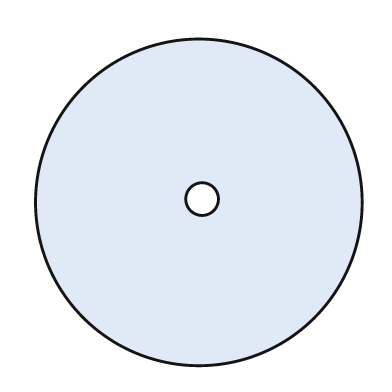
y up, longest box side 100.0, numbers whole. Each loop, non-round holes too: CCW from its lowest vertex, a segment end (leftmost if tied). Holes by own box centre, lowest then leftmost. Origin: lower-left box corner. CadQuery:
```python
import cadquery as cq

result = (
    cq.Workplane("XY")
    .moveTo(50.0, 50.0)
    .circle(50.0)
    .moveTo(51.0, 51.0)
    .circle(5.0)
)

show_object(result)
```